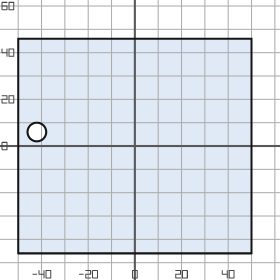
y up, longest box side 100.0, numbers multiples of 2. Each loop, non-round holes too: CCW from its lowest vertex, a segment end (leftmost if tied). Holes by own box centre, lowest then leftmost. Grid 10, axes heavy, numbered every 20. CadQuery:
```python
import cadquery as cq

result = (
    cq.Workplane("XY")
    .moveTo(-50.0, -46.0)
    .lineTo(50.0, -46.0)
    .lineTo(50.0, 46.0)
    .lineTo(-50.0, 46.0)
    .close()
    .moveTo(-42.0, 6.0)
    .circle(4.0)
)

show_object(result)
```